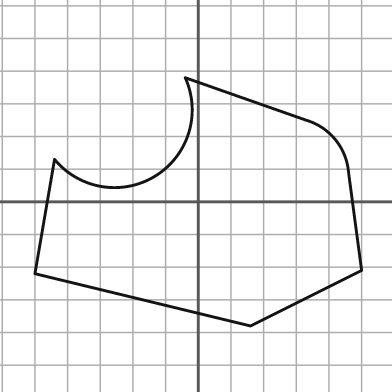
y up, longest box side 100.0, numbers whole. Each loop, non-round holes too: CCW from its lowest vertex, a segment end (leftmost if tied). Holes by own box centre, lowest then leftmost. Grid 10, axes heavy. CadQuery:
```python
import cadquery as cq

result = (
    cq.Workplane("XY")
    .moveTo(16.0, -38.0)
    .lineTo(50.0, -21.0)
    .lineTo(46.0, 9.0)
    .threePointArc((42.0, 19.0), (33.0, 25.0))
    .lineTo(-4.0, 38.0)
    .threePointArc((-13.0, 8.0), (-44.0, 13.0))
    .lineTo(-50.0, -22.0)
    .close()
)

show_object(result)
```